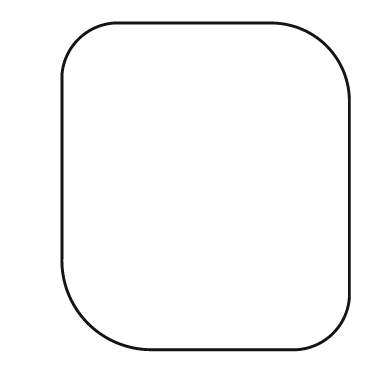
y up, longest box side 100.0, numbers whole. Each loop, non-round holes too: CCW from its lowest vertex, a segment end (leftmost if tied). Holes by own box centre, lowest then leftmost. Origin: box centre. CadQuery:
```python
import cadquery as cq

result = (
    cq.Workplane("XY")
    .moveTo(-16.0, -50.0)
    .lineTo(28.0, -50.0)
    .threePointArc((39.0, -45.0), (44.0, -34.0))
    .lineTo(44.0, 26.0)
    .threePointArc((37.0, 43.0), (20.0, 50.0))
    .lineTo(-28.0, 50.0)
    .threePointArc((-39.0, 45.0), (-44.0, 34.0))
    .lineTo(-44.0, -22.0)
    .threePointArc((-36.0, -42.0), (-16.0, -50.0))
    .close()
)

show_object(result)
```